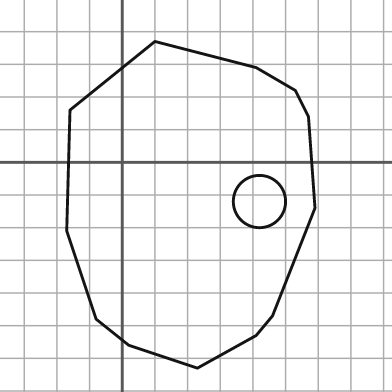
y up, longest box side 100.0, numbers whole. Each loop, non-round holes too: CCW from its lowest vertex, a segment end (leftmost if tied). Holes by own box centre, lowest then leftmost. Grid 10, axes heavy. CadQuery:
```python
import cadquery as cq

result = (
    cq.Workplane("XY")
    .moveTo(23.0, -63.0)
    .lineTo(41.0, -53.0)
    .lineTo(46.0, -47.0)
    .lineTo(59.0, -14.0)
    .lineTo(57.0, 14.0)
    .lineTo(53.0, 22.0)
    .lineTo(41.0, 29.0)
    .lineTo(10.0, 37.0)
    .lineTo(-16.0, 16.0)
    .lineTo(-17.0, -21.0)
    .lineTo(-8.0, -48.0)
    .lineTo(2.0, -56.0)
    .close()
    .moveTo(42.0, -12.0)
    .circle(8.0)
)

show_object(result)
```